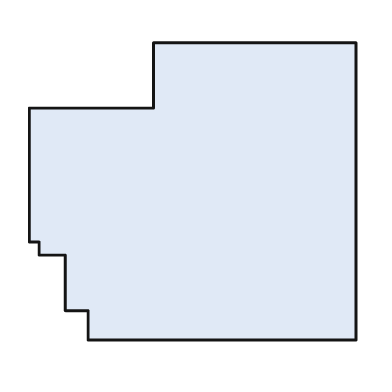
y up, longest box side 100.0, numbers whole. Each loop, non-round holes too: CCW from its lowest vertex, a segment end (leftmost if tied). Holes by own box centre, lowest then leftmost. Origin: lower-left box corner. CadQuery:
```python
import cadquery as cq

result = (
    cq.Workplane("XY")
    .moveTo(18.0, 0.0)
    .lineTo(100.0, 0.0)
    .lineTo(100.0, 91.0)
    .lineTo(38.0, 91.0)
    .lineTo(38.0, 71.0)
    .lineTo(0.0, 71.0)
    .lineTo(0.0, 30.0)
    .lineTo(3.0, 30.0)
    .lineTo(3.0, 26.0)
    .lineTo(11.0, 26.0)
    .lineTo(11.0, 9.0)
    .lineTo(18.0, 9.0)
    .close()
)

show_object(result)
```